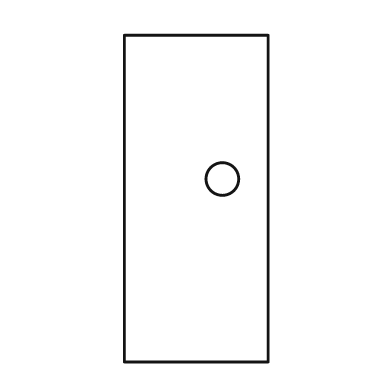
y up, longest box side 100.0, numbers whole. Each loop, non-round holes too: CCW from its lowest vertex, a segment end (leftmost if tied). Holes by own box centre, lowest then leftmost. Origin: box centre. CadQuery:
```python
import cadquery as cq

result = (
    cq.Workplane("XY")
    .moveTo(-22.0, -50.0)
    .lineTo(22.0, -50.0)
    .lineTo(22.0, 50.0)
    .lineTo(-22.0, 50.0)
    .close()
    .moveTo(8.0, 6.0)
    .circle(5.0)
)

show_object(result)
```